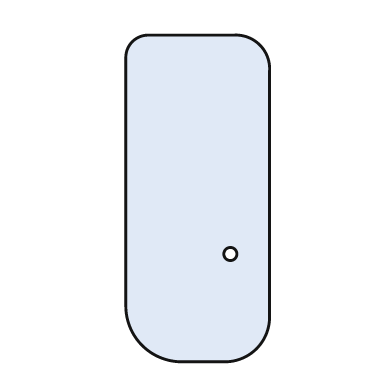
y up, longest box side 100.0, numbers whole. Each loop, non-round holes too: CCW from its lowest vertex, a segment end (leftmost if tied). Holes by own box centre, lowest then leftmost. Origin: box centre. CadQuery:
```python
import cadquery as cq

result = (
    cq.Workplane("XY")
    .moveTo(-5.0, -50.0)
    .lineTo(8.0, -50.0)
    .threePointArc((18.0, -46.0), (22.0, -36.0))
    .lineTo(22.0, 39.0)
    .threePointArc((19.0, 47.0), (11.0, 50.0))
    .lineTo(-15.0, 50.0)
    .threePointArc((-20.0, 48.0), (-22.0, 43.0))
    .lineTo(-22.0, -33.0)
    .threePointArc((-17.0, -45.0), (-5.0, -50.0))
    .close()
    .moveTo(10.0, -17.0)
    .circle(2.0)
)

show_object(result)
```